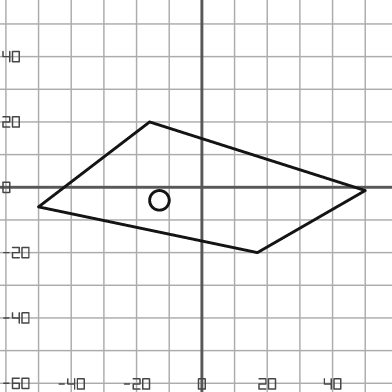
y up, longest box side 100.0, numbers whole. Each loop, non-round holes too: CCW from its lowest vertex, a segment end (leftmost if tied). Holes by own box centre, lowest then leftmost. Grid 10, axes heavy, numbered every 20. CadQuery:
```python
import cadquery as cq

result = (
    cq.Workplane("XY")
    .moveTo(17.0, -20.0)
    .lineTo(50.0, -1.0)
    .lineTo(-16.0, 20.0)
    .lineTo(-50.0, -6.0)
    .close()
    .moveTo(-13.0, -4.0)
    .circle(3.0)
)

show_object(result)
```